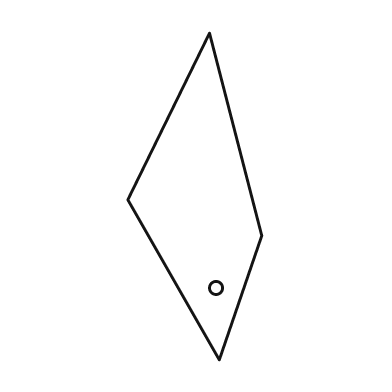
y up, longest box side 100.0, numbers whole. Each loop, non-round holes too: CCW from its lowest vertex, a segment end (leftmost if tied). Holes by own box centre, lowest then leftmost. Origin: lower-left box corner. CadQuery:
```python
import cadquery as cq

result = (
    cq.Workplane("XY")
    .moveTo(28.0, 0.0)
    .lineTo(41.0, 38.0)
    .lineTo(25.0, 100.0)
    .lineTo(0.0, 49.0)
    .close()
    .moveTo(27.0, 22.0)
    .circle(2.0)
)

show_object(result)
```